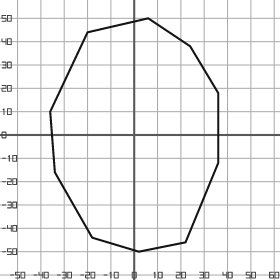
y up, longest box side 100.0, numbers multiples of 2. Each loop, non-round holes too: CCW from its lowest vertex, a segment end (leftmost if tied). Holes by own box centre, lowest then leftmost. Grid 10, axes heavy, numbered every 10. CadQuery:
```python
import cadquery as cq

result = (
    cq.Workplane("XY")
    .moveTo(2.0, -50.0)
    .lineTo(22.0, -46.0)
    .lineTo(36.0, -12.0)
    .lineTo(36.0, 18.0)
    .lineTo(24.0, 38.0)
    .lineTo(6.0, 50.0)
    .lineTo(-20.0, 44.0)
    .lineTo(-36.0, 10.0)
    .lineTo(-34.0, -16.0)
    .lineTo(-18.0, -44.0)
    .close()
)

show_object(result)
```